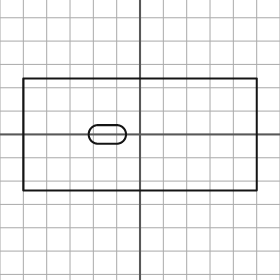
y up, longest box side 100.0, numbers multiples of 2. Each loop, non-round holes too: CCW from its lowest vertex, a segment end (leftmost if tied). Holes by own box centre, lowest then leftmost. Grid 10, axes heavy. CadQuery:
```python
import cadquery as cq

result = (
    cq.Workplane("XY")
    .moveTo(-50.0, -24.0)
    .lineTo(50.0, -24.0)
    .lineTo(50.0, 24.0)
    .lineTo(-50.0, 24.0)
    .close()
    .moveTo(-18.0, -4.0)
    .lineTo(-10.0, -4.0)
    .threePointArc((-6.0, 0.0), (-10.0, 4.0))
    .lineTo(-18.0, 4.0)
    .threePointArc((-22.0, 0.0), (-18.0, -4.0))
    .close()
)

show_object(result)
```